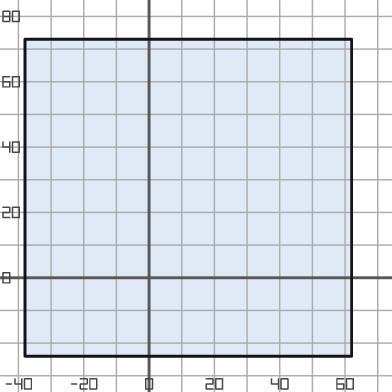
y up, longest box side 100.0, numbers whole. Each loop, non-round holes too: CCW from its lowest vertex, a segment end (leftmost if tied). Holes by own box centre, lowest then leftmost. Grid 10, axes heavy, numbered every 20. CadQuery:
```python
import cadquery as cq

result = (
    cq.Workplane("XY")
    .moveTo(-38.0, -24.0)
    .lineTo(62.0, -24.0)
    .lineTo(62.0, 73.0)
    .lineTo(-38.0, 73.0)
    .close()
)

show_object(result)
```